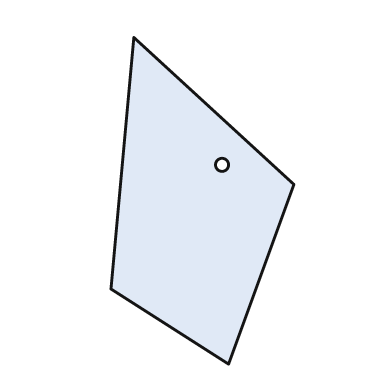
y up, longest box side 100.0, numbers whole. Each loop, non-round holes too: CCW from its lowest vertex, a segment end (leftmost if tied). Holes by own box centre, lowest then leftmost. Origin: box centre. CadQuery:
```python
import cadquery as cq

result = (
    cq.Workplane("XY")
    .moveTo(8.0, -50.0)
    .lineTo(28.0, 5.0)
    .lineTo(-21.0, 50.0)
    .lineTo(-28.0, -27.0)
    .close()
    .moveTo(6.0, 11.0)
    .circle(2.0)
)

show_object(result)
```